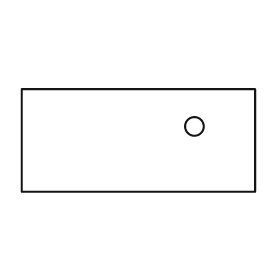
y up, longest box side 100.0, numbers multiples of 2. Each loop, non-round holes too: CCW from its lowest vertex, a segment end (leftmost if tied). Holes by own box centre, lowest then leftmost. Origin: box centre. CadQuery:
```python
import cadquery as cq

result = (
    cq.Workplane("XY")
    .moveTo(-50.0, -22.0)
    .lineTo(50.0, -22.0)
    .lineTo(50.0, 22.0)
    .lineTo(-50.0, 22.0)
    .close()
    .moveTo(24.0, 6.0)
    .circle(4.0)
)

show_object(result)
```